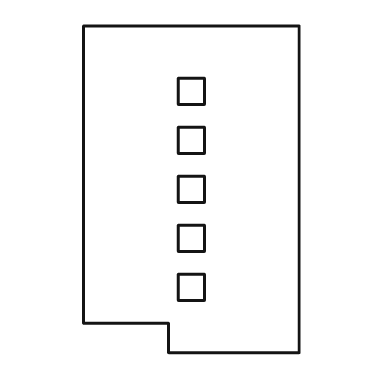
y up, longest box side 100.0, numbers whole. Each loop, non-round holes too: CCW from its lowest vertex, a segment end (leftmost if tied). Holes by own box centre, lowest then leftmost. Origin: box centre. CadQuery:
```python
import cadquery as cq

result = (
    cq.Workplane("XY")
    .moveTo(-7.0, -50.0)
    .lineTo(33.0, -50.0)
    .lineTo(33.0, 50.0)
    .lineTo(-33.0, 50.0)
    .lineTo(-33.0, -41.0)
    .lineTo(-7.0, -41.0)
    .close()
    .moveTo(-4.0, -34.0)
    .lineTo(4.0, -34.0)
    .lineTo(4.0, -26.0)
    .lineTo(-4.0, -26.0)
    .close()
    .moveTo(-4.0, -19.0)
    .lineTo(4.0, -19.0)
    .lineTo(4.0, -11.0)
    .lineTo(-4.0, -11.0)
    .close()
    .moveTo(-4.0, -4.0)
    .lineTo(4.0, -4.0)
    .lineTo(4.0, 4.0)
    .lineTo(-4.0, 4.0)
    .close()
    .moveTo(-4.0, 11.0)
    .lineTo(4.0, 11.0)
    .lineTo(4.0, 19.0)
    .lineTo(-4.0, 19.0)
    .close()
    .moveTo(-4.0, 26.0)
    .lineTo(4.0, 26.0)
    .lineTo(4.0, 34.0)
    .lineTo(-4.0, 34.0)
    .close()
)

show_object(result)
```